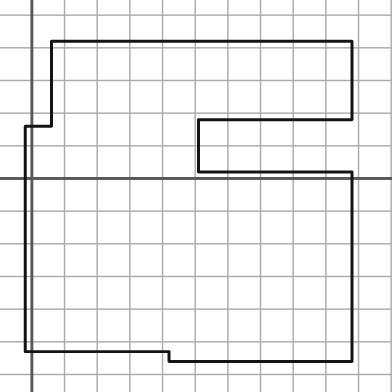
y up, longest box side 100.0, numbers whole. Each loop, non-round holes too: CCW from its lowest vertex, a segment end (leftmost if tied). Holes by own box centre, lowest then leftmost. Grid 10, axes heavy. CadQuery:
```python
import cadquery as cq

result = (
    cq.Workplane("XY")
    .moveTo(42.0, -56.0)
    .lineTo(98.0, -56.0)
    .lineTo(98.0, 2.0)
    .lineTo(51.0, 2.0)
    .lineTo(51.0, 18.0)
    .lineTo(98.0, 18.0)
    .lineTo(98.0, 42.0)
    .lineTo(6.0, 42.0)
    .lineTo(6.0, 16.0)
    .lineTo(-2.0, 16.0)
    .lineTo(-2.0, -53.0)
    .lineTo(42.0, -53.0)
    .close()
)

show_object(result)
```